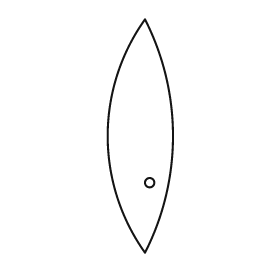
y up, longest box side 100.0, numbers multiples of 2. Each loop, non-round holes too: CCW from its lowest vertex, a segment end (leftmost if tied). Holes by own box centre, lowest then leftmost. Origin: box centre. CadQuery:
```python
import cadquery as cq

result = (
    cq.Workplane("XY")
    .moveTo(2.0, -50.0)
    .threePointArc((14.0, 0.0), (2.0, 50.0))
    .threePointArc((-14.0, 0.0), (2.0, -50.0))
    .close()
    .moveTo(4.0, -20.0)
    .circle(2.0)
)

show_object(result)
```